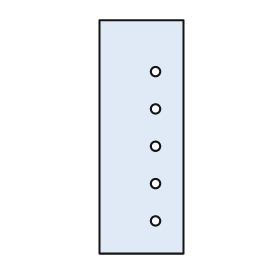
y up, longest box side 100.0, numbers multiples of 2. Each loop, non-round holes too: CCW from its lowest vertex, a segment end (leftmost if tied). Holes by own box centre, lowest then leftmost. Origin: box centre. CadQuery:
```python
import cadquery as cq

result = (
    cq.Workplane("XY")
    .moveTo(-18.0, -50.0)
    .lineTo(18.0, -50.0)
    .lineTo(18.0, 50.0)
    .lineTo(-18.0, 50.0)
    .close()
    .moveTo(6.0, -36.0)
    .circle(2.0)
    .moveTo(6.0, -20.0)
    .circle(2.0)
    .moveTo(6.0, -4.0)
    .circle(2.0)
    .moveTo(6.0, 12.0)
    .circle(2.0)
    .moveTo(6.0, 28.0)
    .circle(2.0)
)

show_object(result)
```